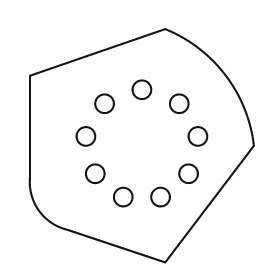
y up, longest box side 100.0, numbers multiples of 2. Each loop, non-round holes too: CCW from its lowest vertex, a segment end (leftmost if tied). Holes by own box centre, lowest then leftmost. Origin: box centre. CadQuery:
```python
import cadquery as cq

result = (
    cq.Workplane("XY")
    .moveTo(10.0, -50.0)
    .lineTo(48.0, 0.0)
    .threePointArc((36.0, 30.0), (10.0, 50.0))
    .lineTo(-48.0, 30.0)
    .lineTo(-48.0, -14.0)
    .threePointArc((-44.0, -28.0), (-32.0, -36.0))
    .close()
    .moveTo(-8.0, -22.0)
    .circle(4.0)
    .moveTo(8.0, -22.0)
    .circle(4.0)
    .moveTo(-20.0, -12.0)
    .circle(4.0)
    .moveTo(20.0, -12.0)
    .circle(4.0)
    .moveTo(-24.0, 4.0)
    .circle(4.0)
    .moveTo(24.0, 4.0)
    .circle(4.0)
    .moveTo(-16.0, 18.0)
    .circle(4.0)
    .moveTo(16.0, 18.0)
    .circle(4.0)
    .moveTo(0.0, 24.0)
    .circle(4.0)
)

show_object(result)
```